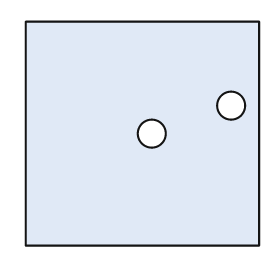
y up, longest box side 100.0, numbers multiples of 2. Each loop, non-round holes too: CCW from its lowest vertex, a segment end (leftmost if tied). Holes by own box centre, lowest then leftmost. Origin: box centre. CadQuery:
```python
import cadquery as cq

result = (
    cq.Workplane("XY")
    .moveTo(-50.0, -48.0)
    .lineTo(50.0, -48.0)
    .lineTo(50.0, 48.0)
    .lineTo(-50.0, 48.0)
    .close()
    .moveTo(4.0, 0.0)
    .circle(6.0)
    .moveTo(38.0, 12.0)
    .circle(6.0)
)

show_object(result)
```